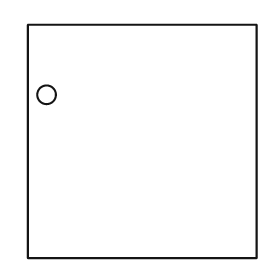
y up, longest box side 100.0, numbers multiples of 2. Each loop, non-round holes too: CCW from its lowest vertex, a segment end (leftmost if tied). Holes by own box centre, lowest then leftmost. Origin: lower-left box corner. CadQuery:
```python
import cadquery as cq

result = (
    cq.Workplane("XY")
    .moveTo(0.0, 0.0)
    .lineTo(98.0, 0.0)
    .lineTo(98.0, 100.0)
    .lineTo(0.0, 100.0)
    .close()
    .moveTo(8.0, 70.0)
    .circle(4.0)
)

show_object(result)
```